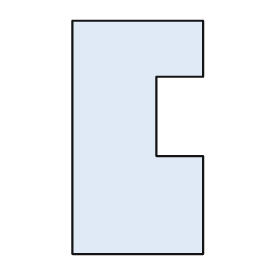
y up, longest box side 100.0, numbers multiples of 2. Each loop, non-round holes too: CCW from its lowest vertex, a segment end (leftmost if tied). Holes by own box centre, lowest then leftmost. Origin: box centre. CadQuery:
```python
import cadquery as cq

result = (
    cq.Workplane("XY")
    .moveTo(-28.0, -50.0)
    .lineTo(28.0, -50.0)
    .lineTo(28.0, -8.0)
    .lineTo(8.0, -8.0)
    .lineTo(8.0, 26.0)
    .lineTo(28.0, 26.0)
    .lineTo(28.0, 50.0)
    .lineTo(-28.0, 50.0)
    .close()
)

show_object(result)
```